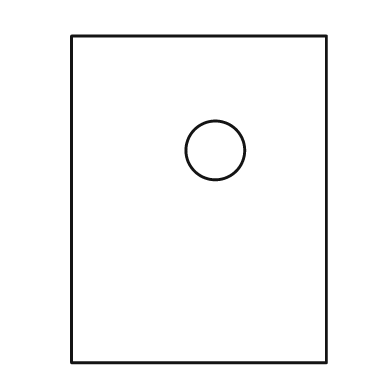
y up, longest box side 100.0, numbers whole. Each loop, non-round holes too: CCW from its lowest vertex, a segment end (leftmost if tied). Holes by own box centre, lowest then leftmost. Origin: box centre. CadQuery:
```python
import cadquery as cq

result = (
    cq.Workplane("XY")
    .moveTo(-39.0, -50.0)
    .lineTo(39.0, -50.0)
    .lineTo(39.0, 50.0)
    .lineTo(-39.0, 50.0)
    .close()
    .moveTo(5.0, 15.0)
    .circle(9.0)
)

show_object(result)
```